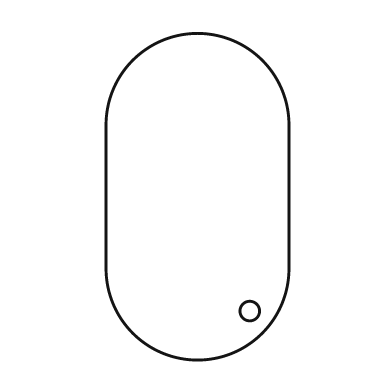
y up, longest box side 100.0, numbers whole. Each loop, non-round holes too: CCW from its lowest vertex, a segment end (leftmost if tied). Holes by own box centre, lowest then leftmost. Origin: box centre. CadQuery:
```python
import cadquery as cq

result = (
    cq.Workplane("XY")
    .moveTo(-28.0, -22.0)
    .threePointArc((0.0, -50.0), (28.0, -22.0))
    .lineTo(28.0, 22.0)
    .threePointArc((0.0, 50.0), (-28.0, 22.0))
    .close()
    .moveTo(16.0, -35.0)
    .circle(3.0)
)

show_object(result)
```